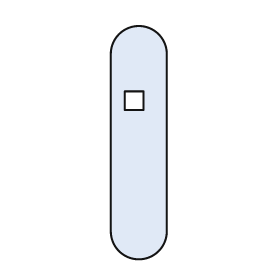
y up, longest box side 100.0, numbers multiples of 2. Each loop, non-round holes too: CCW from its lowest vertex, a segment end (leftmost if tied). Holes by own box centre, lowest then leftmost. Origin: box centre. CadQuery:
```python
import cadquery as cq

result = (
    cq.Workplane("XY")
    .moveTo(-12.0, -38.0)
    .threePointArc((0.0, -50.0), (12.0, -38.0))
    .lineTo(12.0, 38.0)
    .threePointArc((0.0, 50.0), (-12.0, 38.0))
    .close()
    .moveTo(-6.0, 14.0)
    .lineTo(2.0, 14.0)
    .lineTo(2.0, 22.0)
    .lineTo(-6.0, 22.0)
    .close()
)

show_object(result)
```